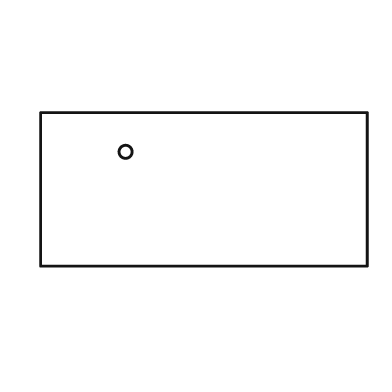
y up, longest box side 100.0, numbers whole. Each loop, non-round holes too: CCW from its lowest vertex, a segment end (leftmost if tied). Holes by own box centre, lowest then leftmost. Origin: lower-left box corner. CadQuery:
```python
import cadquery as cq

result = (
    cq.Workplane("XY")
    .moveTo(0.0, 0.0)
    .lineTo(100.0, 0.0)
    .lineTo(100.0, 47.0)
    .lineTo(0.0, 47.0)
    .close()
    .moveTo(26.0, 35.0)
    .circle(2.0)
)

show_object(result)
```